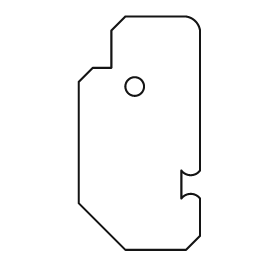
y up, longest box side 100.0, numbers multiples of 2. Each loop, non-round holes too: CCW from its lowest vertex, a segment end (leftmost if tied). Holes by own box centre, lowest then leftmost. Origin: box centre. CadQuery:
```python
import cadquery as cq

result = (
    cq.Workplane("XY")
    .moveTo(-6.0, -50.0)
    .lineTo(20.0, -50.0)
    .lineTo(26.0, -44.0)
    .lineTo(26.0, -28.0)
    .threePointArc((22.0, -26.0), (18.0, -28.0))
    .lineTo(18.0, -16.0)
    .threePointArc((22.0, -18.0), (26.0, -16.0))
    .lineTo(26.0, 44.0)
    .threePointArc((24.0, 48.0), (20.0, 50.0))
    .lineTo(-6.0, 50.0)
    .lineTo(-12.0, 44.0)
    .lineTo(-12.0, 28.0)
    .lineTo(-20.0, 28.0)
    .lineTo(-26.0, 22.0)
    .lineTo(-26.0, -30.0)
    .close()
    .moveTo(-2.0, 20.0)
    .circle(4.0)
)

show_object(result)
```